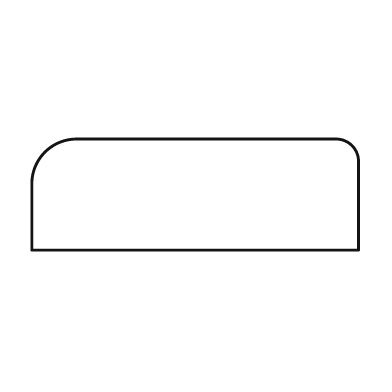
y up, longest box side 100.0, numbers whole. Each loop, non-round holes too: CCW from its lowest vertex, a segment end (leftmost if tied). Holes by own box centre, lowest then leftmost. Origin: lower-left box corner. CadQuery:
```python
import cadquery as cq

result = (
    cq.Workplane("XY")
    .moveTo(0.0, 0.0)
    .lineTo(100.0, 0.0)
    .lineTo(100.0, 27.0)
    .threePointArc((98.0, 32.0), (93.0, 34.0))
    .lineTo(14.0, 34.0)
    .threePointArc((4.0, 30.0), (0.0, 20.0))
    .close()
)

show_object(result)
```